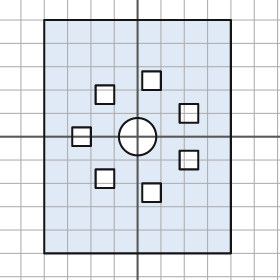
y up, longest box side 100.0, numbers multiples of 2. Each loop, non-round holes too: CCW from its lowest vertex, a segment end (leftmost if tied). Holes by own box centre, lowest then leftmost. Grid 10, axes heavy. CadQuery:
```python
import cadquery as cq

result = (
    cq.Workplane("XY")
    .moveTo(-40.0, -50.0)
    .lineTo(40.0, -50.0)
    .lineTo(40.0, 50.0)
    .lineTo(-40.0, 50.0)
    .close()
    .moveTo(2.0, -28.0)
    .lineTo(10.0, -28.0)
    .lineTo(10.0, -20.0)
    .lineTo(2.0, -20.0)
    .close()
    .moveTo(-18.0, -22.0)
    .lineTo(-10.0, -22.0)
    .lineTo(-10.0, -14.0)
    .lineTo(-18.0, -14.0)
    .close()
    .moveTo(18.0, -14.0)
    .lineTo(26.0, -14.0)
    .lineTo(26.0, -6.0)
    .lineTo(18.0, -6.0)
    .close()
    .moveTo(-28.0, -4.0)
    .lineTo(-20.0, -4.0)
    .lineTo(-20.0, 4.0)
    .lineTo(-28.0, 4.0)
    .close()
    .moveTo(0.0, 0.0)
    .circle(8.0)
    .moveTo(18.0, 6.0)
    .lineTo(26.0, 6.0)
    .lineTo(26.0, 14.0)
    .lineTo(18.0, 14.0)
    .close()
    .moveTo(-18.0, 14.0)
    .lineTo(-10.0, 14.0)
    .lineTo(-10.0, 22.0)
    .lineTo(-18.0, 22.0)
    .close()
    .moveTo(2.0, 20.0)
    .lineTo(10.0, 20.0)
    .lineTo(10.0, 28.0)
    .lineTo(2.0, 28.0)
    .close()
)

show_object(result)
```